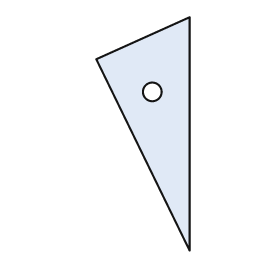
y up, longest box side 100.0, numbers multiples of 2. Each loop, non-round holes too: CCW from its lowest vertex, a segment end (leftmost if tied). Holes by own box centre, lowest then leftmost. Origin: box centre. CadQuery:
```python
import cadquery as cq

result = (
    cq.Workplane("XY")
    .moveTo(20.0, -50.0)
    .lineTo(20.0, 50.0)
    .lineTo(-20.0, 32.0)
    .close()
    .moveTo(4.0, 18.0)
    .circle(4.0)
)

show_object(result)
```